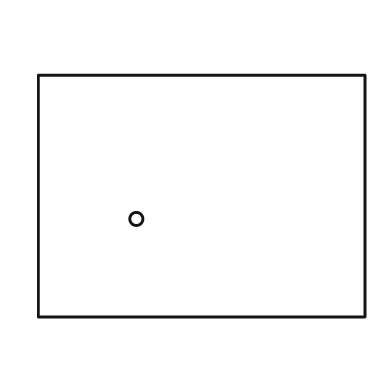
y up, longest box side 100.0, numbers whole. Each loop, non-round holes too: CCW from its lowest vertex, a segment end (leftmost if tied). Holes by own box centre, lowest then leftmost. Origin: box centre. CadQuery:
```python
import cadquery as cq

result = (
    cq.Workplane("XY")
    .moveTo(-50.0, -37.0)
    .lineTo(50.0, -37.0)
    .lineTo(50.0, 37.0)
    .lineTo(-50.0, 37.0)
    .close()
    .moveTo(-20.0, -7.0)
    .circle(2.0)
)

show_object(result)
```